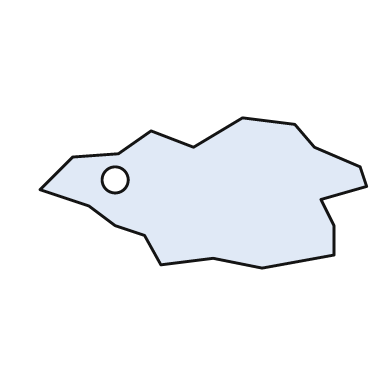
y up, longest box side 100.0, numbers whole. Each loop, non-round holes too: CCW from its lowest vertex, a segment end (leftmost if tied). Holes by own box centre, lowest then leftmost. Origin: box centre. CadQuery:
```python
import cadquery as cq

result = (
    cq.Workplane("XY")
    .moveTo(18.0, -23.0)
    .lineTo(40.0, -19.0)
    .lineTo(40.0, -10.0)
    .lineTo(36.0, -2.0)
    .lineTo(50.0, 2.0)
    .lineTo(48.0, 8.0)
    .lineTo(34.0, 14.0)
    .lineTo(28.0, 21.0)
    .lineTo(12.0, 23.0)
    .lineTo(-3.0, 14.0)
    .lineTo(-16.0, 19.0)
    .lineTo(-26.0, 12.0)
    .lineTo(-40.0, 11.0)
    .lineTo(-50.0, 1.0)
    .lineTo(-35.0, -4.0)
    .lineTo(-27.0, -10.0)
    .lineTo(-18.0, -13.0)
    .lineTo(-13.0, -22.0)
    .lineTo(3.0, -20.0)
    .close()
    .moveTo(-27.0, 4.0)
    .circle(4.0)
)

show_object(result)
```